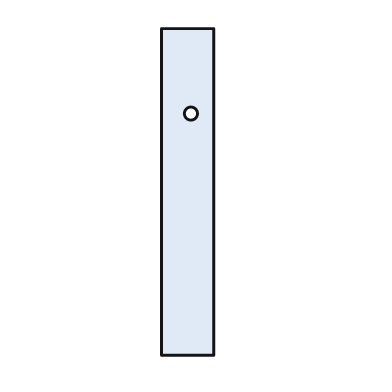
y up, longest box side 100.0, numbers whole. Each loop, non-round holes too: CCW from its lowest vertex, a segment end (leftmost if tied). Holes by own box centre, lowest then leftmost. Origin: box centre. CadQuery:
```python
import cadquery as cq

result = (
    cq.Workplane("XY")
    .moveTo(-8.0, -50.0)
    .lineTo(8.0, -50.0)
    .lineTo(8.0, 50.0)
    .lineTo(-8.0, 50.0)
    .close()
    .moveTo(1.0, 24.0)
    .circle(2.0)
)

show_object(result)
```